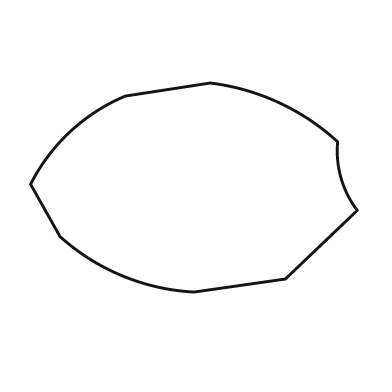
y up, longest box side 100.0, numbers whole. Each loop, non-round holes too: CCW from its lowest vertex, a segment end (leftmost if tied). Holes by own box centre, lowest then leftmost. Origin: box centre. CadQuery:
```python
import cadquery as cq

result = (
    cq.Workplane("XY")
    .moveTo(0.0, -32.0)
    .lineTo(28.0, -28.0)
    .lineTo(50.0, -7.0)
    .threePointArc((45.0, 3.0), (44.0, 14.0))
    .threePointArc((26.0, 26.0), (5.0, 32.0))
    .lineTo(-21.0, 28.0)
    .threePointArc((-38.0, 17.0), (-50.0, 1.0))
    .lineTo(-41.0, -15.0)
    .threePointArc((-22.0, -27.0), (0.0, -32.0))
    .close()
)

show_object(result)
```